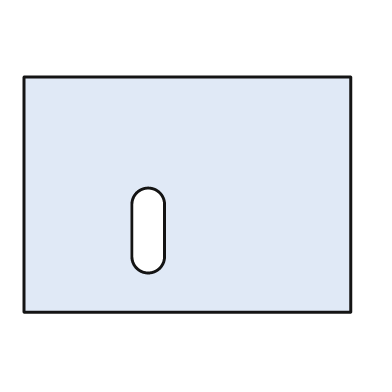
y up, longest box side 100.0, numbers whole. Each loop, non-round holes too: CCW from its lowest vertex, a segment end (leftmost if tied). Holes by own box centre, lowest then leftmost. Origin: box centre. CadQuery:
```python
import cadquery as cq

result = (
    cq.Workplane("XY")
    .moveTo(-50.0, -36.0)
    .lineTo(50.0, -36.0)
    .lineTo(50.0, 36.0)
    .lineTo(-50.0, 36.0)
    .close()
    .moveTo(-17.0, -19.0)
    .threePointArc((-12.0, -24.0), (-7.0, -19.0))
    .lineTo(-7.0, -3.0)
    .threePointArc((-12.0, 2.0), (-17.0, -3.0))
    .close()
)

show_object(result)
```